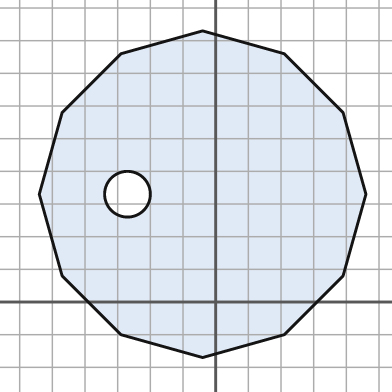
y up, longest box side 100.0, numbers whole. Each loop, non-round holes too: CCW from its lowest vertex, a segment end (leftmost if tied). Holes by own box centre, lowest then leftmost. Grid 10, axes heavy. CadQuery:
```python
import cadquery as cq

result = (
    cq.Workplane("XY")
    .moveTo(-4.0, -17.0)
    .lineTo(21.0, -10.0)
    .lineTo(39.0, 8.0)
    .lineTo(46.0, 33.0)
    .lineTo(39.0, 58.0)
    .lineTo(21.0, 76.0)
    .lineTo(-4.0, 83.0)
    .lineTo(-29.0, 76.0)
    .lineTo(-47.0, 58.0)
    .lineTo(-54.0, 33.0)
    .lineTo(-47.0, 8.0)
    .lineTo(-29.0, -10.0)
    .close()
    .moveTo(-27.0, 33.0)
    .circle(7.0)
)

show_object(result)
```